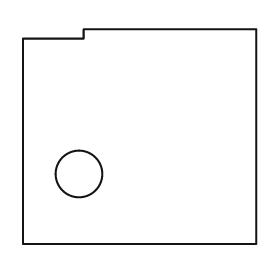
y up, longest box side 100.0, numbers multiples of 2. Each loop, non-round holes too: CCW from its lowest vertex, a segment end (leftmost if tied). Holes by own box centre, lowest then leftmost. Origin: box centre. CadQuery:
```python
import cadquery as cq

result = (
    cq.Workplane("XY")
    .moveTo(-50.0, -46.0)
    .lineTo(50.0, -46.0)
    .lineTo(50.0, 46.0)
    .lineTo(-24.0, 46.0)
    .lineTo(-24.0, 42.0)
    .lineTo(-50.0, 42.0)
    .close()
    .moveTo(-26.0, -16.0)
    .circle(10.0)
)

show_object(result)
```